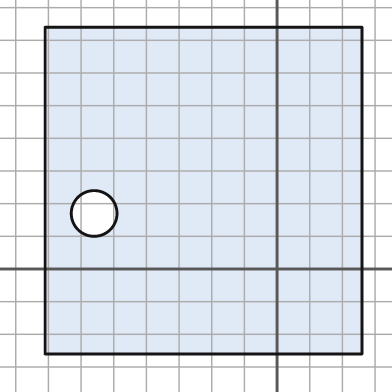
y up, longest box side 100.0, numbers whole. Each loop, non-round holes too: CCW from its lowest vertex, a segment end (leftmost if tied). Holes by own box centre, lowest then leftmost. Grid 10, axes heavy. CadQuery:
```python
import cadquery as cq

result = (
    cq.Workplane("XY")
    .moveTo(-71.0, -26.0)
    .lineTo(26.0, -26.0)
    .lineTo(26.0, 74.0)
    .lineTo(-71.0, 74.0)
    .close()
    .moveTo(-56.0, 17.0)
    .circle(7.0)
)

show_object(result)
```